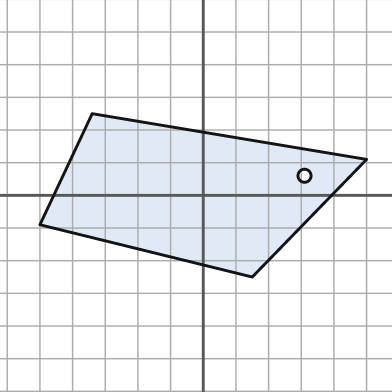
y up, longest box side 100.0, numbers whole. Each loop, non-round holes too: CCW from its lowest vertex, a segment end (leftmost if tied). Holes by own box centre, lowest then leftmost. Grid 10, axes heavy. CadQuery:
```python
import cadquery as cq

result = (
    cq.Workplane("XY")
    .moveTo(15.0, -25.0)
    .lineTo(50.0, 11.0)
    .lineTo(-34.0, 25.0)
    .lineTo(-50.0, -9.0)
    .close()
    .moveTo(31.0, 6.0)
    .circle(2.0)
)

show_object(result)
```